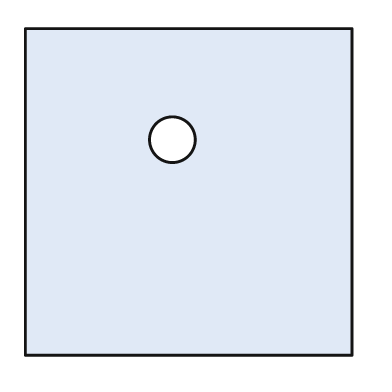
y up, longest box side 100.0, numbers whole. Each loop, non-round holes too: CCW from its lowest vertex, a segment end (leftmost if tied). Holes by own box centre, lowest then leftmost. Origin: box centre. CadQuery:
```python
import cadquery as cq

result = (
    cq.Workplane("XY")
    .moveTo(-50.0, -50.0)
    .lineTo(50.0, -50.0)
    .lineTo(50.0, 50.0)
    .lineTo(-50.0, 50.0)
    .close()
    .moveTo(-5.0, 16.0)
    .circle(7.0)
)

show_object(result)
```